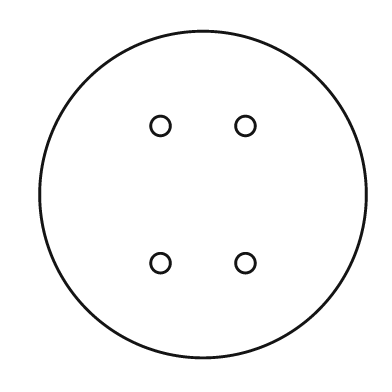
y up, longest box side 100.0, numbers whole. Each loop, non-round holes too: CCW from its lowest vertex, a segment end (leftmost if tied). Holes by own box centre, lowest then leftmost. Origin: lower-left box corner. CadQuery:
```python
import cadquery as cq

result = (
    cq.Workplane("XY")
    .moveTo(50.0, 50.0)
    .circle(50.0)
    .moveTo(37.0, 29.0)
    .circle(3.0)
    .moveTo(63.0, 29.0)
    .circle(3.0)
    .moveTo(37.0, 71.0)
    .circle(3.0)
    .moveTo(63.0, 71.0)
    .circle(3.0)
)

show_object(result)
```